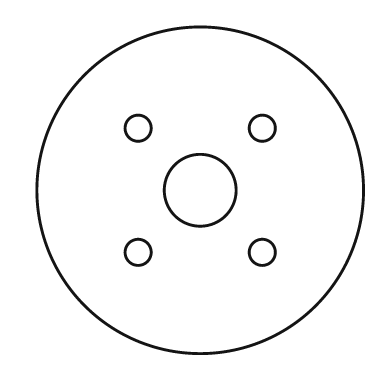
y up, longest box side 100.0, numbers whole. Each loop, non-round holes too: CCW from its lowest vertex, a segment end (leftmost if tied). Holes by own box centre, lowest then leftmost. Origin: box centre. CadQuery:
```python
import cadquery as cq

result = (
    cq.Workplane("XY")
    .moveTo(0.0, 0.0)
    .circle(50.0)
    .moveTo(-19.0, -19.0)
    .circle(4.0)
    .moveTo(19.0, -19.0)
    .circle(4.0)
    .moveTo(0.0, 0.0)
    .circle(11.0)
    .moveTo(-19.0, 19.0)
    .circle(4.0)
    .moveTo(19.0, 19.0)
    .circle(4.0)
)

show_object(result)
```